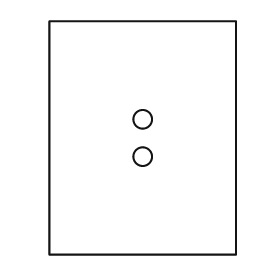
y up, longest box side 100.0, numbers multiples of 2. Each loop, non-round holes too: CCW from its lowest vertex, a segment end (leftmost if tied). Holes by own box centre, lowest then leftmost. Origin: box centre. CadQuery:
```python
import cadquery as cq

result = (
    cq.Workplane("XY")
    .moveTo(-40.0, -50.0)
    .lineTo(40.0, -50.0)
    .lineTo(40.0, 50.0)
    .lineTo(-40.0, 50.0)
    .close()
    .moveTo(0.0, -8.0)
    .circle(4.0)
    .moveTo(0.0, 8.0)
    .circle(4.0)
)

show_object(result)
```